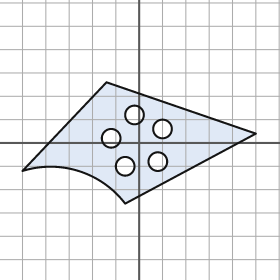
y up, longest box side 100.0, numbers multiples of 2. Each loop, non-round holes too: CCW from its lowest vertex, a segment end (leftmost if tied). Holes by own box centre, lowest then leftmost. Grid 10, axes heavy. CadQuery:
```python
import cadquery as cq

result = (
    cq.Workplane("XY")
    .moveTo(-6.0, -26.0)
    .lineTo(50.0, 4.0)
    .lineTo(-14.0, 26.0)
    .lineTo(-50.0, -12.0)
    .threePointArc((-26.0, -12.0), (-6.0, -26.0))
    .close()
    .moveTo(-6.0, -10.0)
    .circle(4.0)
    .moveTo(8.0, -8.0)
    .circle(4.0)
    .moveTo(-12.0, 2.0)
    .circle(4.0)
    .moveTo(10.0, 6.0)
    .circle(4.0)
    .moveTo(-2.0, 12.0)
    .circle(4.0)
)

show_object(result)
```